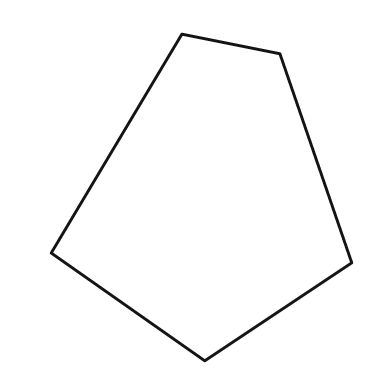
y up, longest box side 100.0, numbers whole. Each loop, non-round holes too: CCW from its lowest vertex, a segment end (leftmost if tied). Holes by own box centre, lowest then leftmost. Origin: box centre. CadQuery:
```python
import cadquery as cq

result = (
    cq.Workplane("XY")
    .moveTo(1.0, -50.0)
    .lineTo(46.0, -20.0)
    .lineTo(24.0, 44.0)
    .lineTo(-6.0, 50.0)
    .lineTo(-46.0, -17.0)
    .close()
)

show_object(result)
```